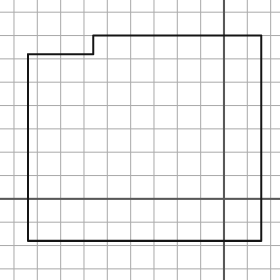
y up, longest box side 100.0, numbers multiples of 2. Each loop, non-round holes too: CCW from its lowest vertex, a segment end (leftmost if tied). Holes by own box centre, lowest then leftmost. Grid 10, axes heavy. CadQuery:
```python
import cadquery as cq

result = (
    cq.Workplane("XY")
    .moveTo(-84.0, -18.0)
    .lineTo(16.0, -18.0)
    .lineTo(16.0, 70.0)
    .lineTo(-56.0, 70.0)
    .lineTo(-56.0, 62.0)
    .lineTo(-84.0, 62.0)
    .close()
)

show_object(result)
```